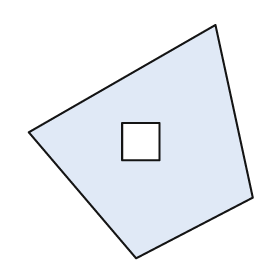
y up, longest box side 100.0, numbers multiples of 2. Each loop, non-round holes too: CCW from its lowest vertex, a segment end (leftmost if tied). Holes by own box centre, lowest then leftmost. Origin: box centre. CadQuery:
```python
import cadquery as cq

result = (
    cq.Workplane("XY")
    .moveTo(-2.0, -50.0)
    .lineTo(48.0, -24.0)
    .lineTo(32.0, 50.0)
    .lineTo(-48.0, 4.0)
    .close()
    .moveTo(-8.0, -8.0)
    .lineTo(8.0, -8.0)
    .lineTo(8.0, 8.0)
    .lineTo(-8.0, 8.0)
    .close()
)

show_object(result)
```